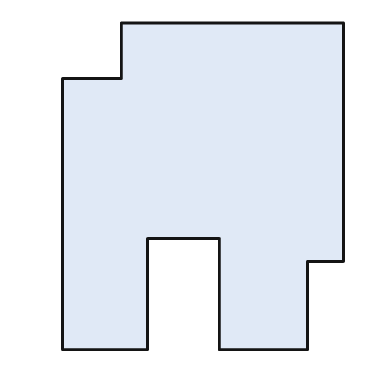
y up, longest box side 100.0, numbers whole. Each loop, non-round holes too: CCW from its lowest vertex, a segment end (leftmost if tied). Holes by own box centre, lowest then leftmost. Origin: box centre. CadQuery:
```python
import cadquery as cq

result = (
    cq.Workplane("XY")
    .moveTo(-43.0, -50.0)
    .lineTo(-17.0, -50.0)
    .lineTo(-17.0, -16.0)
    .lineTo(5.0, -16.0)
    .lineTo(5.0, -50.0)
    .lineTo(32.0, -50.0)
    .lineTo(32.0, -23.0)
    .lineTo(43.0, -23.0)
    .lineTo(43.0, 50.0)
    .lineTo(-25.0, 50.0)
    .lineTo(-25.0, 33.0)
    .lineTo(-43.0, 33.0)
    .close()
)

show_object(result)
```